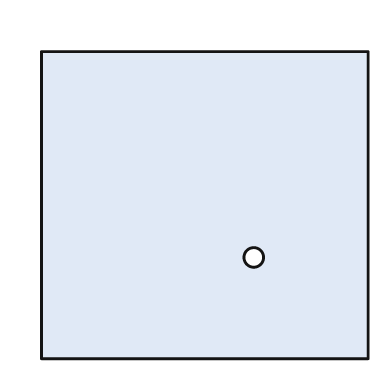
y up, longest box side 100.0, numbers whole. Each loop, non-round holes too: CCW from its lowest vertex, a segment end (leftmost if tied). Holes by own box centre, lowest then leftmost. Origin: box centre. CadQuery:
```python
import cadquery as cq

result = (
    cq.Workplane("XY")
    .moveTo(-50.0, -47.0)
    .lineTo(50.0, -47.0)
    .lineTo(50.0, 47.0)
    .lineTo(-50.0, 47.0)
    .close()
    .moveTo(15.0, -16.0)
    .circle(3.0)
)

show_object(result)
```